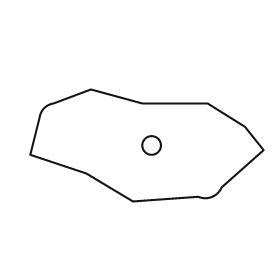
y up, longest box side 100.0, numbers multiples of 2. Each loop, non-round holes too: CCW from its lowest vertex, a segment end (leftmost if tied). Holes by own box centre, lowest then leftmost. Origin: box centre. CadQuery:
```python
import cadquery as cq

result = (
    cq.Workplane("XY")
    .moveTo(-6.0, -24.0)
    .lineTo(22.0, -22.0)
    .threePointArc((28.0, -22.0), (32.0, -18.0))
    .lineTo(50.0, -2.0)
    .lineTo(42.0, 8.0)
    .lineTo(26.0, 18.0)
    .lineTo(-2.0, 18.0)
    .lineTo(-24.0, 24.0)
    .lineTo(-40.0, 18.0)
    .threePointArc((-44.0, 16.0), (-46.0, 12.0))
    .lineTo(-50.0, -4.0)
    .lineTo(-26.0, -12.0)
    .close()
    .moveTo(2.0, 0.0)
    .circle(4.0)
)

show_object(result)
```